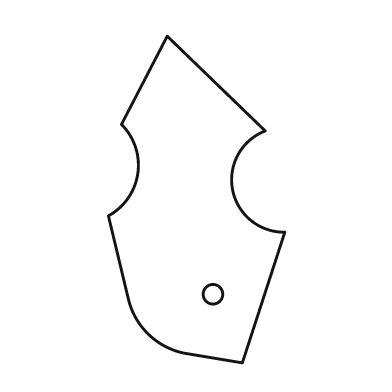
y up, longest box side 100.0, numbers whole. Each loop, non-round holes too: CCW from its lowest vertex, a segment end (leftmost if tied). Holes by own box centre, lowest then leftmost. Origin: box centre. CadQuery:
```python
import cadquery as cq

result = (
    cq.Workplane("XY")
    .moveTo(14.0, -50.0)
    .lineTo(27.0, -10.0)
    .threePointArc((11.0, 3.0), (21.0, 21.0))
    .lineTo(-9.0, 50.0)
    .lineTo(-23.0, 23.0)
    .threePointArc((-18.0, 8.0), (-27.0, -5.0))
    .lineTo(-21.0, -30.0)
    .threePointArc((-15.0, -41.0), (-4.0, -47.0))
    .close()
    .moveTo(5.0, -29.0)
    .circle(3.0)
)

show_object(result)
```